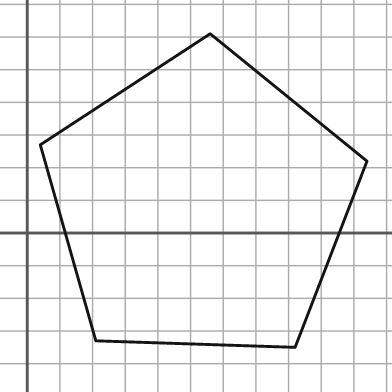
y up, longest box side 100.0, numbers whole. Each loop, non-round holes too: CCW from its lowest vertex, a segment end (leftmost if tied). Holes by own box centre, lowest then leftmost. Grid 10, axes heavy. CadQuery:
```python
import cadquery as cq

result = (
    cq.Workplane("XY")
    .moveTo(82.0, -35.0)
    .lineTo(104.0, 22.0)
    .lineTo(56.0, 61.0)
    .lineTo(4.0, 27.0)
    .lineTo(21.0, -33.0)
    .close()
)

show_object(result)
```